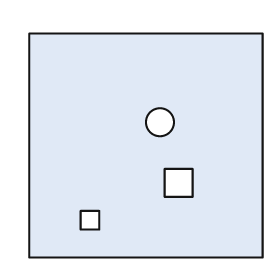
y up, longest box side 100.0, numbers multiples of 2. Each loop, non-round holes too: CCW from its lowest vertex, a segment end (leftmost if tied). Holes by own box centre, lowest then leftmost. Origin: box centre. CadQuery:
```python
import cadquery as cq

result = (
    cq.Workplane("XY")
    .moveTo(-50.0, -48.0)
    .lineTo(50.0, -48.0)
    .lineTo(50.0, 48.0)
    .lineTo(-50.0, 48.0)
    .close()
    .moveTo(-28.0, -36.0)
    .lineTo(-20.0, -36.0)
    .lineTo(-20.0, -28.0)
    .lineTo(-28.0, -28.0)
    .close()
    .moveTo(8.0, -22.0)
    .lineTo(20.0, -22.0)
    .lineTo(20.0, -10.0)
    .lineTo(8.0, -10.0)
    .close()
    .moveTo(6.0, 10.0)
    .circle(6.0)
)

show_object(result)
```